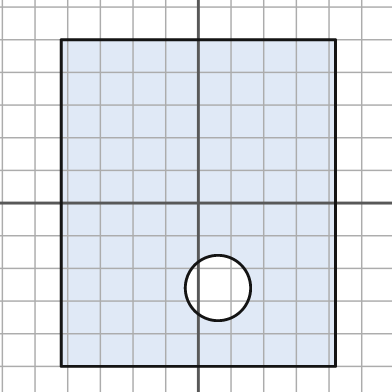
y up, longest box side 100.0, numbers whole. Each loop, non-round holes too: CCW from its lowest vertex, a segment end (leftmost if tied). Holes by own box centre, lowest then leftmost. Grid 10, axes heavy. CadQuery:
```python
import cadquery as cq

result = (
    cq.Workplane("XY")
    .moveTo(-42.0, -50.0)
    .lineTo(42.0, -50.0)
    .lineTo(42.0, 50.0)
    .lineTo(-42.0, 50.0)
    .close()
    .moveTo(6.0, -26.0)
    .circle(10.0)
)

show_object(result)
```